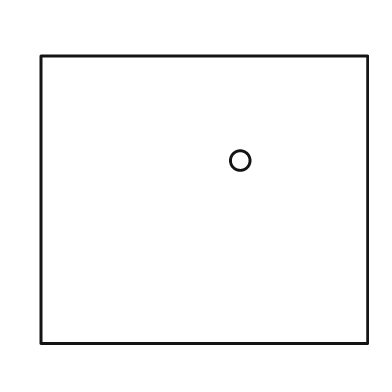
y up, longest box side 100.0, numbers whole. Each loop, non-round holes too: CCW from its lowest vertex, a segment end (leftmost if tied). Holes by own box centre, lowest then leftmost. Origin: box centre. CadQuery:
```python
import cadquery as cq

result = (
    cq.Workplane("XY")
    .moveTo(-50.0, -44.0)
    .lineTo(50.0, -44.0)
    .lineTo(50.0, 44.0)
    .lineTo(-50.0, 44.0)
    .close()
    .moveTo(11.0, 12.0)
    .circle(3.0)
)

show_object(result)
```